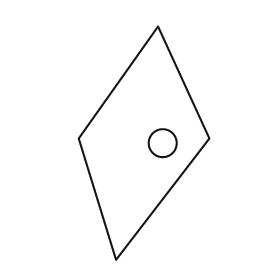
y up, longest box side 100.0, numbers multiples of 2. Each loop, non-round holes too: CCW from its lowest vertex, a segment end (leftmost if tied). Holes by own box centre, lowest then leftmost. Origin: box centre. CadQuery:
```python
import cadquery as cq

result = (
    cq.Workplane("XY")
    .moveTo(-12.0, -50.0)
    .lineTo(28.0, 2.0)
    .lineTo(6.0, 50.0)
    .lineTo(-28.0, 2.0)
    .close()
    .moveTo(8.0, 0.0)
    .circle(6.0)
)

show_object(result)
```